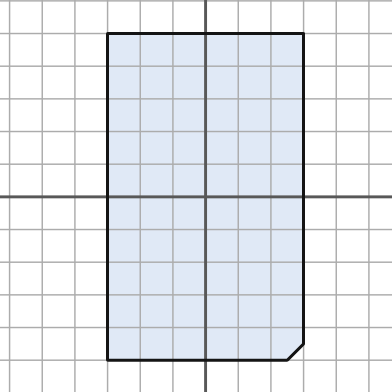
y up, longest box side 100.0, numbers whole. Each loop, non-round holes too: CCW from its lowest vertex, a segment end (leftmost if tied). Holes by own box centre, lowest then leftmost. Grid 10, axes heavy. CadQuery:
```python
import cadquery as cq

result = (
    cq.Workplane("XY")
    .moveTo(-30.0, -50.0)
    .lineTo(25.0, -50.0)
    .lineTo(30.0, -45.0)
    .lineTo(30.0, 50.0)
    .lineTo(-30.0, 50.0)
    .close()
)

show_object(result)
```